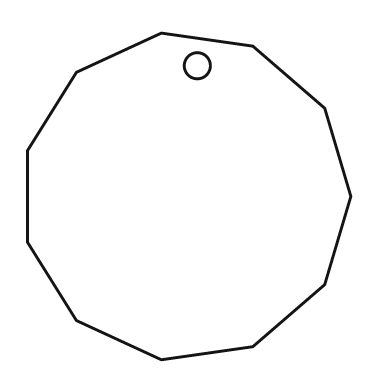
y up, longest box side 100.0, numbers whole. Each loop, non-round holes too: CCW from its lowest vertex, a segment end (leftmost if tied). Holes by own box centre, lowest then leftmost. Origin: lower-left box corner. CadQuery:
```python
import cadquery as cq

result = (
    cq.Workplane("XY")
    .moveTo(41.0, 0.0)
    .lineTo(69.0, 4.0)
    .lineTo(91.0, 23.0)
    .lineTo(99.0, 50.0)
    .lineTo(91.0, 77.0)
    .lineTo(69.0, 96.0)
    .lineTo(41.0, 100.0)
    .lineTo(15.0, 88.0)
    .lineTo(0.0, 64.0)
    .lineTo(0.0, 36.0)
    .lineTo(15.0, 12.0)
    .close()
    .moveTo(52.0, 90.0)
    .circle(4.0)
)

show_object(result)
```